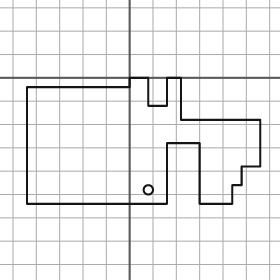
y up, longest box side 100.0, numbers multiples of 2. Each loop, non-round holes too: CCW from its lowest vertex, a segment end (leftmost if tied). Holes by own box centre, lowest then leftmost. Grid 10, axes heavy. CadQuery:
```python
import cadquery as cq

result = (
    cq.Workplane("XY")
    .moveTo(-44.0, -54.0)
    .lineTo(16.0, -54.0)
    .lineTo(16.0, -28.0)
    .lineTo(30.0, -28.0)
    .lineTo(30.0, -54.0)
    .lineTo(44.0, -54.0)
    .lineTo(44.0, -46.0)
    .lineTo(48.0, -46.0)
    .lineTo(48.0, -38.0)
    .lineTo(56.0, -38.0)
    .lineTo(56.0, -18.0)
    .lineTo(22.0, -18.0)
    .lineTo(22.0, 0.0)
    .lineTo(16.0, 0.0)
    .lineTo(16.0, -12.0)
    .lineTo(8.0, -12.0)
    .lineTo(8.0, 0.0)
    .lineTo(0.0, 0.0)
    .lineTo(0.0, -4.0)
    .lineTo(-44.0, -4.0)
    .close()
    .moveTo(8.0, -48.0)
    .circle(2.0)
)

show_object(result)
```